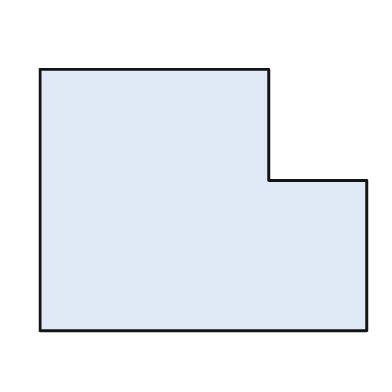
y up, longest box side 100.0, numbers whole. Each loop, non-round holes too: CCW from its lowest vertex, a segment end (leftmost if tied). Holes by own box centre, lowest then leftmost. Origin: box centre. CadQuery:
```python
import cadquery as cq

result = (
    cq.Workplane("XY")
    .moveTo(-50.0, -40.0)
    .lineTo(50.0, -40.0)
    .lineTo(50.0, 6.0)
    .lineTo(20.0, 6.0)
    .lineTo(20.0, 40.0)
    .lineTo(-50.0, 40.0)
    .close()
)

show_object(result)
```